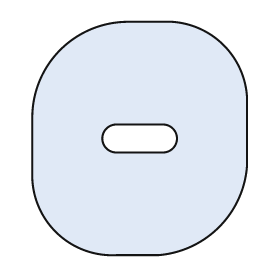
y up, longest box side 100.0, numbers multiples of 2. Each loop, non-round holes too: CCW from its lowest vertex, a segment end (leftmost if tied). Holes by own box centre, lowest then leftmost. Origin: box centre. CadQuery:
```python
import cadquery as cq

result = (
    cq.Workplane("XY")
    .moveTo(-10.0, -50.0)
    .lineTo(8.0, -50.0)
    .threePointArc((34.0, -38.0), (46.0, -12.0))
    .lineTo(46.0, 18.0)
    .threePointArc((36.0, 40.0), (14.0, 50.0))
    .lineTo(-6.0, 50.0)
    .threePointArc((-34.0, 38.0), (-46.0, 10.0))
    .lineTo(-46.0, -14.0)
    .threePointArc((-36.0, -40.0), (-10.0, -50.0))
    .close()
    .moveTo(-10.0, -6.0)
    .lineTo(10.0, -6.0)
    .threePointArc((16.0, 0.0), (10.0, 6.0))
    .lineTo(-10.0, 6.0)
    .threePointArc((-16.0, 0.0), (-10.0, -6.0))
    .close()
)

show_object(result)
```